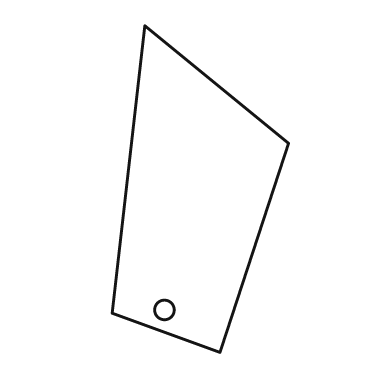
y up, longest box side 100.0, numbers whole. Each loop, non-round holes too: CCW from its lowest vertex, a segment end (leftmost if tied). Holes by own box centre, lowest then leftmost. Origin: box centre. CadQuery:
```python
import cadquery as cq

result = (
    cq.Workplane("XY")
    .moveTo(6.0, -50.0)
    .lineTo(27.0, 14.0)
    .lineTo(-17.0, 50.0)
    .lineTo(-27.0, -38.0)
    .close()
    .moveTo(-11.0, -37.0)
    .circle(3.0)
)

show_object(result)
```